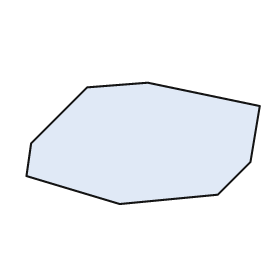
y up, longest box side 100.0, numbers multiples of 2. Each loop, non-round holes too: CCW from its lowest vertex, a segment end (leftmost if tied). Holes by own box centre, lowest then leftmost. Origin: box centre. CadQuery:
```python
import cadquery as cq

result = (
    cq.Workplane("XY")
    .moveTo(-10.0, -26.0)
    .lineTo(32.0, -22.0)
    .lineTo(46.0, -8.0)
    .lineTo(50.0, 16.0)
    .lineTo(2.0, 26.0)
    .lineTo(-24.0, 24.0)
    .lineTo(-48.0, 0.0)
    .lineTo(-50.0, -14.0)
    .close()
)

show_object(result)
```